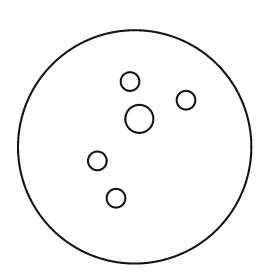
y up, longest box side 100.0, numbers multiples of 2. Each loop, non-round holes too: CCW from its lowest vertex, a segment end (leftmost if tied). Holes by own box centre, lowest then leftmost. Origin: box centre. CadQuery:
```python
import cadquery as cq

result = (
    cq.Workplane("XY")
    .moveTo(0.0, 0.0)
    .circle(50.0)
    .moveTo(-8.0, -22.0)
    .circle(4.0)
    .moveTo(-16.0, -6.0)
    .circle(4.0)
    .moveTo(2.0, 12.0)
    .circle(6.0)
    .moveTo(22.0, 20.0)
    .circle(4.0)
    .moveTo(-2.0, 28.0)
    .circle(4.0)
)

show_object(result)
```